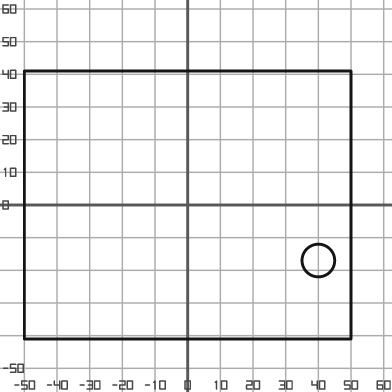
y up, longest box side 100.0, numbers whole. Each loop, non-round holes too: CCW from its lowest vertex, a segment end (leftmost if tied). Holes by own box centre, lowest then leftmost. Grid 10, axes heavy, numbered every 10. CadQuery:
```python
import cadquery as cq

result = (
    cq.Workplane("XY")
    .moveTo(-50.0, -41.0)
    .lineTo(50.0, -41.0)
    .lineTo(50.0, 41.0)
    .lineTo(-50.0, 41.0)
    .close()
    .moveTo(40.0, -17.0)
    .circle(5.0)
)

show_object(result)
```